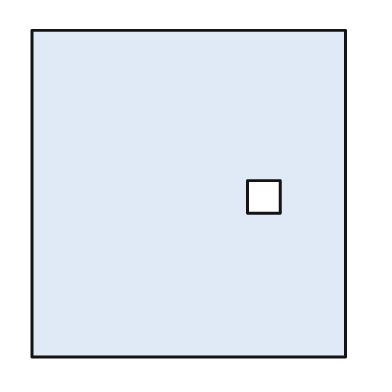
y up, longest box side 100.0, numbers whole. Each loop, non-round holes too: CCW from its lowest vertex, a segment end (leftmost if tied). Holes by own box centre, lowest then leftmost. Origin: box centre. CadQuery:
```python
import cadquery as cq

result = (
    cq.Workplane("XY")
    .moveTo(-48.0, -50.0)
    .lineTo(48.0, -50.0)
    .lineTo(48.0, 50.0)
    .lineTo(-48.0, 50.0)
    .close()
    .moveTo(18.0, -6.0)
    .lineTo(28.0, -6.0)
    .lineTo(28.0, 4.0)
    .lineTo(18.0, 4.0)
    .close()
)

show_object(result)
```